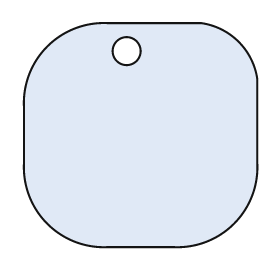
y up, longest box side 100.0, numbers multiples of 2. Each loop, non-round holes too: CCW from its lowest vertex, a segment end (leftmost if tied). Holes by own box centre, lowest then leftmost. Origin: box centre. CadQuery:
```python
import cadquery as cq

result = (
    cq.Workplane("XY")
    .moveTo(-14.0, -48.0)
    .lineTo(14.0, -48.0)
    .threePointArc((40.0, -38.0), (50.0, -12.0))
    .lineTo(50.0, 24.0)
    .threePointArc((42.0, 40.0), (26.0, 48.0))
    .lineTo(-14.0, 48.0)
    .threePointArc((-40.0, 38.0), (-50.0, 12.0))
    .lineTo(-50.0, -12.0)
    .threePointArc((-40.0, -38.0), (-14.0, -48.0))
    .close()
    .moveTo(-6.0, 36.0)
    .circle(6.0)
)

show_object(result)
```